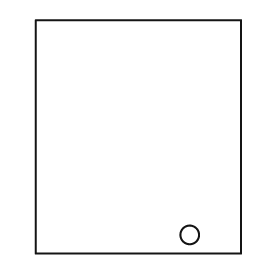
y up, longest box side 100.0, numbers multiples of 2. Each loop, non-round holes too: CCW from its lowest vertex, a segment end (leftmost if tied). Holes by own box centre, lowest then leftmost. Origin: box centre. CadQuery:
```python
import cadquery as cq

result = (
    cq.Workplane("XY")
    .moveTo(-44.0, -50.0)
    .lineTo(44.0, -50.0)
    .lineTo(44.0, 50.0)
    .lineTo(-44.0, 50.0)
    .close()
    .moveTo(22.0, -42.0)
    .circle(4.0)
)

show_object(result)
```